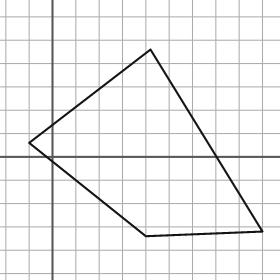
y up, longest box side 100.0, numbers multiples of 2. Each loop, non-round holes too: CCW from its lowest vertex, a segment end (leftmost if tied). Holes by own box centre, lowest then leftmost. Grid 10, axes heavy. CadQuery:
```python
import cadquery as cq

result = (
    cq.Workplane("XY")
    .moveTo(40.0, -34.0)
    .lineTo(90.0, -32.0)
    .lineTo(42.0, 46.0)
    .lineTo(-10.0, 6.0)
    .close()
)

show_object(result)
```